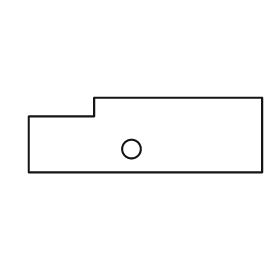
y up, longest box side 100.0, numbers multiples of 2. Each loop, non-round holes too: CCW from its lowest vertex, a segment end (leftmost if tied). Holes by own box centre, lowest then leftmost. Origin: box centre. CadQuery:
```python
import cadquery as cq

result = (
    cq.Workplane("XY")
    .moveTo(-50.0, -16.0)
    .lineTo(50.0, -16.0)
    .lineTo(50.0, 16.0)
    .lineTo(-22.0, 16.0)
    .lineTo(-22.0, 8.0)
    .lineTo(-50.0, 8.0)
    .close()
    .moveTo(-6.0, -6.0)
    .circle(4.0)
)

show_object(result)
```